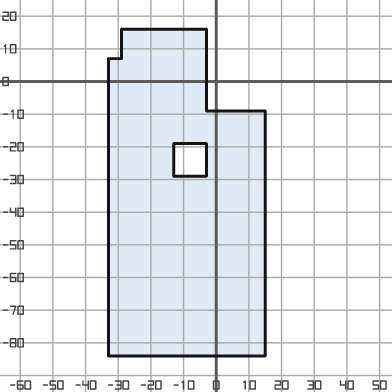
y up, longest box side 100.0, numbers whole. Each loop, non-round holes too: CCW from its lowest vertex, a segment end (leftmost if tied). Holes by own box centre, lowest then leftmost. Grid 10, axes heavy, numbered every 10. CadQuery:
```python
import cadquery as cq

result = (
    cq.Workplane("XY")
    .moveTo(-33.0, -84.0)
    .lineTo(15.0, -84.0)
    .lineTo(15.0, -9.0)
    .lineTo(-3.0, -9.0)
    .lineTo(-3.0, 16.0)
    .lineTo(-29.0, 16.0)
    .lineTo(-29.0, 7.0)
    .lineTo(-33.0, 7.0)
    .close()
    .moveTo(-13.0, -29.0)
    .lineTo(-3.0, -29.0)
    .lineTo(-3.0, -19.0)
    .lineTo(-13.0, -19.0)
    .close()
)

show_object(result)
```